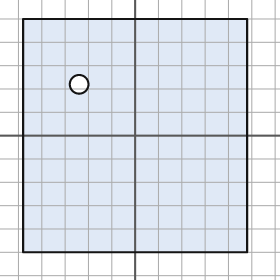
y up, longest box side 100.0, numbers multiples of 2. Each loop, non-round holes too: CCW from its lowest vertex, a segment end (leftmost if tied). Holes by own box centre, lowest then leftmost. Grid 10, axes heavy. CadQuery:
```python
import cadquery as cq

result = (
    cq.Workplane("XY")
    .moveTo(-48.0, -50.0)
    .lineTo(48.0, -50.0)
    .lineTo(48.0, 50.0)
    .lineTo(-48.0, 50.0)
    .close()
    .moveTo(-24.0, 22.0)
    .circle(4.0)
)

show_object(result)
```